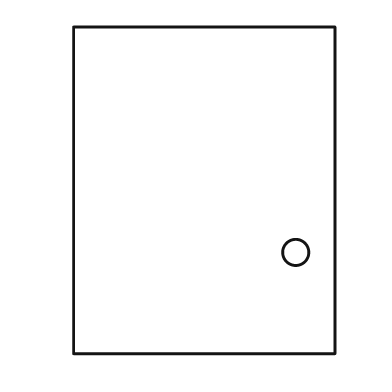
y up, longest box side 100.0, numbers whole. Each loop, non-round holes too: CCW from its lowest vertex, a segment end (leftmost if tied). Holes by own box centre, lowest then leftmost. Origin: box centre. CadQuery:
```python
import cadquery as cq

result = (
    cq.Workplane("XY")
    .moveTo(-40.0, -50.0)
    .lineTo(40.0, -50.0)
    .lineTo(40.0, 50.0)
    .lineTo(-40.0, 50.0)
    .close()
    .moveTo(28.0, -19.0)
    .circle(4.0)
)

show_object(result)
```